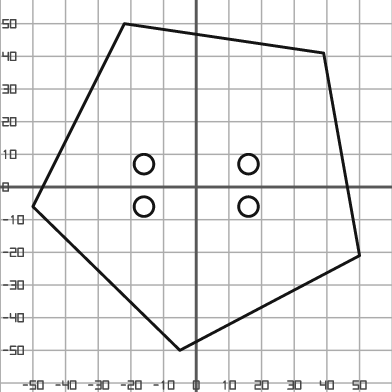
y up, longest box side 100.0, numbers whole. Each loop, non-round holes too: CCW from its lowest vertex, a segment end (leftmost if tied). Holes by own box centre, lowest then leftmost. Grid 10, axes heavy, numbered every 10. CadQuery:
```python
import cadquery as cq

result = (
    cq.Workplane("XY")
    .moveTo(-5.0, -50.0)
    .lineTo(50.0, -21.0)
    .lineTo(39.0, 41.0)
    .lineTo(-22.0, 50.0)
    .lineTo(-50.0, -6.0)
    .close()
    .moveTo(-16.0, -6.0)
    .circle(3.0)
    .moveTo(16.0, -6.0)
    .circle(3.0)
    .moveTo(-16.0, 7.0)
    .circle(3.0)
    .moveTo(16.0, 7.0)
    .circle(3.0)
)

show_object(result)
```